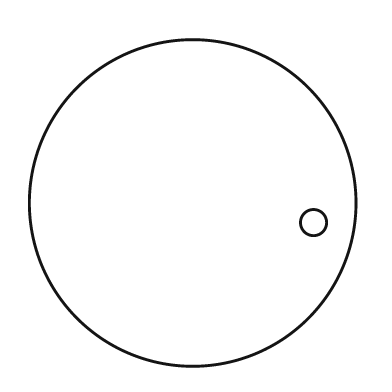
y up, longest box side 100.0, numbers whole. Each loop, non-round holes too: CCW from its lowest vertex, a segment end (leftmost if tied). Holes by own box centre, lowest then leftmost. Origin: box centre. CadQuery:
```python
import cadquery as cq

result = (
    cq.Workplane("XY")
    .moveTo(0.0, 0.0)
    .circle(50.0)
    .moveTo(37.0, -6.0)
    .circle(4.0)
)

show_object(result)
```